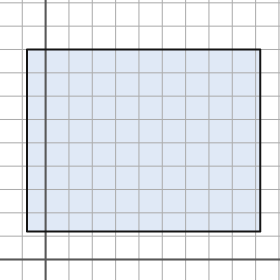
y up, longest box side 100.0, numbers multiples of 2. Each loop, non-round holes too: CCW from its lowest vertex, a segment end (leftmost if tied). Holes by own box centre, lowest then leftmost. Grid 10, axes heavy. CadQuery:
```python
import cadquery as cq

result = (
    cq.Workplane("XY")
    .moveTo(-8.0, 12.0)
    .lineTo(92.0, 12.0)
    .lineTo(92.0, 90.0)
    .lineTo(-8.0, 90.0)
    .close()
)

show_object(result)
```